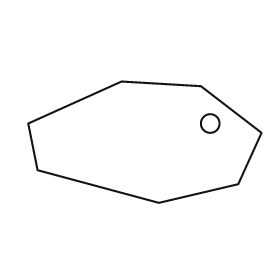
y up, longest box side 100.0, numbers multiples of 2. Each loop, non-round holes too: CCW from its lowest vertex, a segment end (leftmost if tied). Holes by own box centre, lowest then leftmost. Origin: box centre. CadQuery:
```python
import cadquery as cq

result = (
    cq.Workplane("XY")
    .moveTo(6.0, -26.0)
    .lineTo(40.0, -18.0)
    .lineTo(50.0, 4.0)
    .lineTo(24.0, 24.0)
    .lineTo(-10.0, 26.0)
    .lineTo(-50.0, 8.0)
    .lineTo(-46.0, -12.0)
    .close()
    .moveTo(28.0, 8.0)
    .circle(4.0)
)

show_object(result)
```